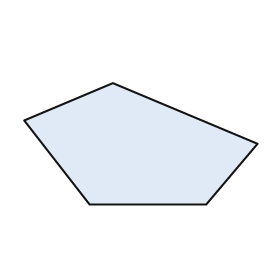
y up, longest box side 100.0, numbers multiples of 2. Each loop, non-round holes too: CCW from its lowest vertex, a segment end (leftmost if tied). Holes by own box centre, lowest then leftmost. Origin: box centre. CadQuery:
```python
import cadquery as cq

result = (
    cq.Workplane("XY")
    .moveTo(-22.0, -26.0)
    .lineTo(28.0, -26.0)
    .lineTo(50.0, 0.0)
    .lineTo(-12.0, 26.0)
    .lineTo(-50.0, 10.0)
    .close()
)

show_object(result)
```